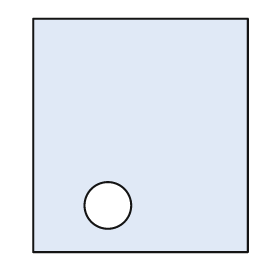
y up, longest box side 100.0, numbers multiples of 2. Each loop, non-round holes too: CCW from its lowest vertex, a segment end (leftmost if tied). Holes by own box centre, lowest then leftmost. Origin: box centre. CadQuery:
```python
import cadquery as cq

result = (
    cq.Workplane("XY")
    .moveTo(-46.0, -50.0)
    .lineTo(46.0, -50.0)
    .lineTo(46.0, 50.0)
    .lineTo(-46.0, 50.0)
    .close()
    .moveTo(-14.0, -30.0)
    .circle(10.0)
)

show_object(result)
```